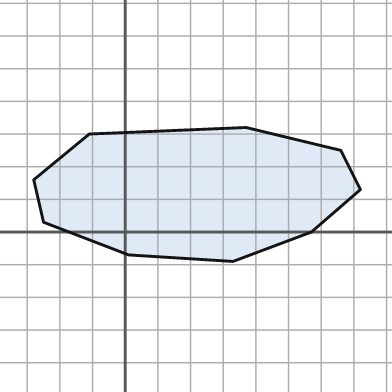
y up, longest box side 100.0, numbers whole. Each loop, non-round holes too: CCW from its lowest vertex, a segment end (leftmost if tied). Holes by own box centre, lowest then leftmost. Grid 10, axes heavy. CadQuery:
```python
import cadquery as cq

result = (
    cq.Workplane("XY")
    .moveTo(33.0, -9.0)
    .lineTo(57.0, 0.0)
    .lineTo(72.0, 13.0)
    .lineTo(66.0, 25.0)
    .lineTo(37.0, 32.0)
    .lineTo(-11.0, 30.0)
    .lineTo(-28.0, 16.0)
    .lineTo(-25.0, 3.0)
    .lineTo(1.0, -7.0)
    .close()
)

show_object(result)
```